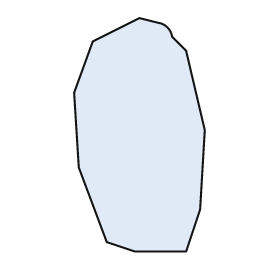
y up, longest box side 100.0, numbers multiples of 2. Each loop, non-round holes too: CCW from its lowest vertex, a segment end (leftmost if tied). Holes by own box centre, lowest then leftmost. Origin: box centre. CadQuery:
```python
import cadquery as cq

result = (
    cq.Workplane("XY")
    .moveTo(-2.0, -50.0)
    .lineTo(20.0, -50.0)
    .lineTo(26.0, -32.0)
    .lineTo(28.0, 2.0)
    .lineTo(20.0, 36.0)
    .lineTo(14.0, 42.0)
    .threePointArc((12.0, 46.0), (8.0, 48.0))
    .lineTo(0.0, 50.0)
    .lineTo(-20.0, 40.0)
    .lineTo(-28.0, 18.0)
    .lineTo(-26.0, -14.0)
    .lineTo(-14.0, -46.0)
    .close()
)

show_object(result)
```